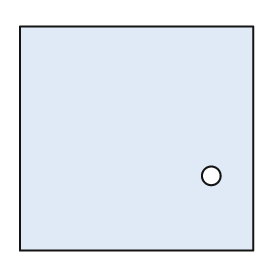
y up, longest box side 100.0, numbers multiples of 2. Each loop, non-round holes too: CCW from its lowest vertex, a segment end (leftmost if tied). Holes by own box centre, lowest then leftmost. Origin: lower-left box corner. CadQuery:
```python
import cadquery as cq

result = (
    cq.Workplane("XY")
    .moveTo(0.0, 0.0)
    .lineTo(100.0, 0.0)
    .lineTo(100.0, 96.0)
    .lineTo(0.0, 96.0)
    .close()
    .moveTo(82.0, 32.0)
    .circle(4.0)
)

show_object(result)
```